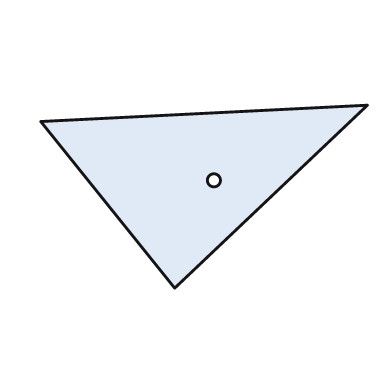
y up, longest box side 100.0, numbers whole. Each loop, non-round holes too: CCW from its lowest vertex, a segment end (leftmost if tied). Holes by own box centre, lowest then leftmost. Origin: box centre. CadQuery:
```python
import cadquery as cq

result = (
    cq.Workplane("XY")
    .moveTo(-9.0, -28.0)
    .lineTo(50.0, 28.0)
    .lineTo(-50.0, 23.0)
    .close()
    .moveTo(3.0, 5.0)
    .circle(2.0)
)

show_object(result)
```